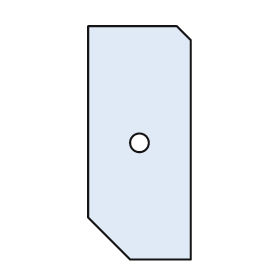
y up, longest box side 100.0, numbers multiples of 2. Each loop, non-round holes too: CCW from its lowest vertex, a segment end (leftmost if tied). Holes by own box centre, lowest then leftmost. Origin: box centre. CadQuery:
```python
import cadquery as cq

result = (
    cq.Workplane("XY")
    .moveTo(-4.0, -50.0)
    .lineTo(22.0, -50.0)
    .lineTo(22.0, 44.0)
    .lineTo(16.0, 50.0)
    .lineTo(-22.0, 50.0)
    .lineTo(-22.0, -32.0)
    .close()
    .moveTo(0.0, 0.0)
    .circle(4.0)
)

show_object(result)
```